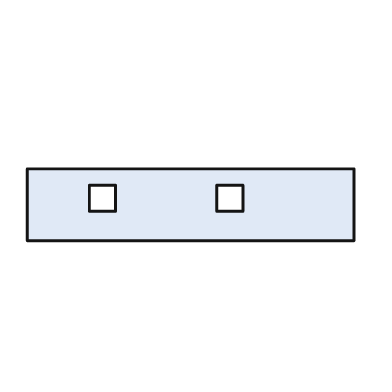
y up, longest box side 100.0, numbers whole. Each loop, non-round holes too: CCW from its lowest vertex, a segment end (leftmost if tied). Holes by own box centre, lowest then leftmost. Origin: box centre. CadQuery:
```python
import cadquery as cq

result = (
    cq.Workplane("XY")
    .moveTo(-50.0, -11.0)
    .lineTo(50.0, -11.0)
    .lineTo(50.0, 11.0)
    .lineTo(-50.0, 11.0)
    .close()
    .moveTo(-31.0, -2.0)
    .lineTo(-23.0, -2.0)
    .lineTo(-23.0, 6.0)
    .lineTo(-31.0, 6.0)
    .close()
    .moveTo(8.0, -2.0)
    .lineTo(16.0, -2.0)
    .lineTo(16.0, 6.0)
    .lineTo(8.0, 6.0)
    .close()
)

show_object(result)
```